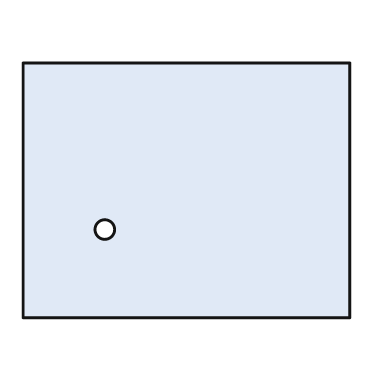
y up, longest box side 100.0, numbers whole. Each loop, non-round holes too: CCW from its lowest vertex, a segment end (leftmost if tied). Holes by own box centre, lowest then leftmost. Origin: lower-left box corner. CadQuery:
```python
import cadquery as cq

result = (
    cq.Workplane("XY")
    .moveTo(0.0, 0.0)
    .lineTo(100.0, 0.0)
    .lineTo(100.0, 78.0)
    .lineTo(0.0, 78.0)
    .close()
    .moveTo(25.0, 27.0)
    .circle(3.0)
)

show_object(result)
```